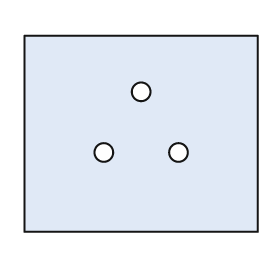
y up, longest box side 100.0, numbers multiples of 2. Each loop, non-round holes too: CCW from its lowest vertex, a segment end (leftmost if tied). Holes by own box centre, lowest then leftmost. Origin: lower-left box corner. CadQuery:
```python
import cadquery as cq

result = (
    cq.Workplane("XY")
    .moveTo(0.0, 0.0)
    .lineTo(100.0, 0.0)
    .lineTo(100.0, 84.0)
    .lineTo(0.0, 84.0)
    .close()
    .moveTo(34.0, 34.0)
    .circle(4.0)
    .moveTo(66.0, 34.0)
    .circle(4.0)
    .moveTo(50.0, 60.0)
    .circle(4.0)
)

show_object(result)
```